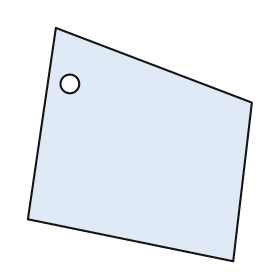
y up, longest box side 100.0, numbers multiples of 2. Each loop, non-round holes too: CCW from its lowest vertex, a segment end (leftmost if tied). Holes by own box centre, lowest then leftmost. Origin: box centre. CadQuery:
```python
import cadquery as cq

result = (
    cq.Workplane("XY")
    .moveTo(40.0, -50.0)
    .lineTo(48.0, 18.0)
    .lineTo(-36.0, 50.0)
    .lineTo(-48.0, -32.0)
    .close()
    .moveTo(-30.0, 26.0)
    .circle(4.0)
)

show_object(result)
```